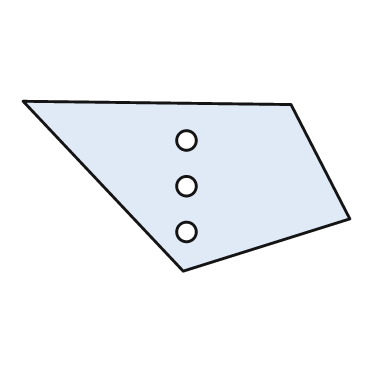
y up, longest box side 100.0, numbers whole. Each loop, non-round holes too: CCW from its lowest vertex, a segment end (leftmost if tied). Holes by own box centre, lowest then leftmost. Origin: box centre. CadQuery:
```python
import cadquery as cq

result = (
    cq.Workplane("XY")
    .moveTo(-1.0, -26.0)
    .lineTo(50.0, -10.0)
    .lineTo(32.0, 25.0)
    .lineTo(-50.0, 26.0)
    .close()
    .moveTo(0.0, -14.0)
    .circle(3.0)
    .moveTo(0.0, 0.0)
    .circle(3.0)
    .moveTo(0.0, 14.0)
    .circle(3.0)
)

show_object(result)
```